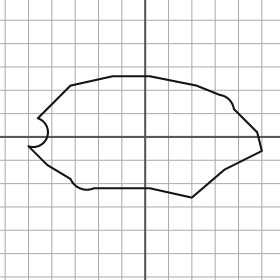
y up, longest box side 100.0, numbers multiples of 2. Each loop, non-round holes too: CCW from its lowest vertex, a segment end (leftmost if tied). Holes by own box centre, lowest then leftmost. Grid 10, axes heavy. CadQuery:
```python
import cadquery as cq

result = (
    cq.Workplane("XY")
    .moveTo(20.0, -26.0)
    .lineTo(34.0, -14.0)
    .lineTo(50.0, -6.0)
    .lineTo(48.0, 2.0)
    .lineTo(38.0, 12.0)
    .threePointArc((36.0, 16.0), (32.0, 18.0))
    .lineTo(22.0, 22.0)
    .lineTo(2.0, 26.0)
    .lineTo(-14.0, 26.0)
    .lineTo(-32.0, 22.0)
    .lineTo(-46.0, 8.0)
    .threePointArc((-42.0, 0.0), (-50.0, -4.0))
    .lineTo(-42.0, -12.0)
    .lineTo(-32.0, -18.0)
    .threePointArc((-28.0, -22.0), (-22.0, -22.0))
    .lineTo(2.0, -22.0)
    .close()
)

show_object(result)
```